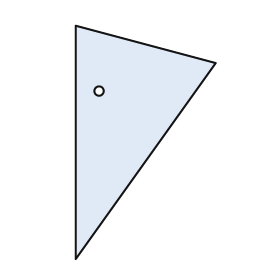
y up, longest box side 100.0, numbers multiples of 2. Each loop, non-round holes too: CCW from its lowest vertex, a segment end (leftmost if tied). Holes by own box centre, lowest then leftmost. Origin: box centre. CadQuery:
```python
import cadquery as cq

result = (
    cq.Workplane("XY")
    .moveTo(-30.0, -50.0)
    .lineTo(30.0, 34.0)
    .lineTo(-30.0, 50.0)
    .close()
    .moveTo(-20.0, 22.0)
    .circle(2.0)
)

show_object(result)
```